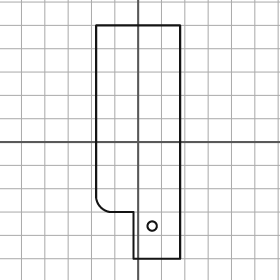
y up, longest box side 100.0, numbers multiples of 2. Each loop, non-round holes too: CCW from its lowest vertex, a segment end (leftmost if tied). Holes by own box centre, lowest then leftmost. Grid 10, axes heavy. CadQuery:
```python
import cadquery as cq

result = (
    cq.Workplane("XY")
    .moveTo(-2.0, -50.0)
    .lineTo(18.0, -50.0)
    .lineTo(18.0, 50.0)
    .lineTo(-18.0, 50.0)
    .lineTo(-18.0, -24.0)
    .threePointArc((-16.0, -28.0), (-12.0, -30.0))
    .lineTo(-2.0, -30.0)
    .close()
    .moveTo(6.0, -36.0)
    .circle(2.0)
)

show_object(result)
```